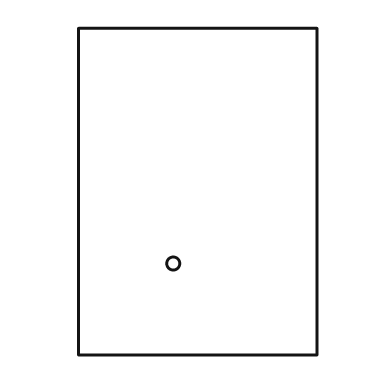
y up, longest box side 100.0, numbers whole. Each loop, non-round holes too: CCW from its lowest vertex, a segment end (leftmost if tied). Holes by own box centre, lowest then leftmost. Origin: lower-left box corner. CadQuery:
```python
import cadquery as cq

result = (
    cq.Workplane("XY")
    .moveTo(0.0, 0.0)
    .lineTo(73.0, 0.0)
    .lineTo(73.0, 100.0)
    .lineTo(0.0, 100.0)
    .close()
    .moveTo(29.0, 28.0)
    .circle(2.0)
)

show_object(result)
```